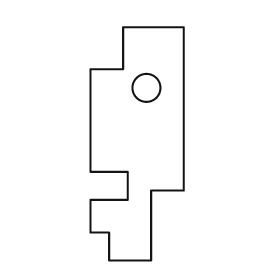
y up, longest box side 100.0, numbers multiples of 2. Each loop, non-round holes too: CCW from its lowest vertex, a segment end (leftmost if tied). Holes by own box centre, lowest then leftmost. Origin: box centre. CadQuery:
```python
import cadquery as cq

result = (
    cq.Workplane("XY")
    .moveTo(-12.0, -50.0)
    .lineTo(6.0, -50.0)
    .lineTo(6.0, -20.0)
    .lineTo(20.0, -20.0)
    .lineTo(20.0, 50.0)
    .lineTo(-6.0, 50.0)
    .lineTo(-6.0, 32.0)
    .lineTo(-20.0, 32.0)
    .lineTo(-20.0, -12.0)
    .lineTo(-4.0, -12.0)
    .lineTo(-4.0, -24.0)
    .lineTo(-20.0, -24.0)
    .lineTo(-20.0, -38.0)
    .lineTo(-12.0, -38.0)
    .close()
    .moveTo(4.0, 24.0)
    .circle(6.0)
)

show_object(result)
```